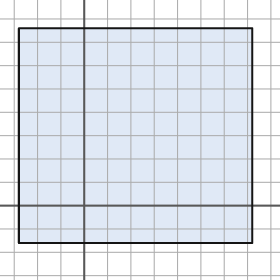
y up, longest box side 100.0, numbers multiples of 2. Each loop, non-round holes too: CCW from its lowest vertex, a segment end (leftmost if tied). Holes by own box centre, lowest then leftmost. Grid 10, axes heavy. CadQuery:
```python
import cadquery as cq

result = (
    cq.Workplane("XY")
    .moveTo(-28.0, -16.0)
    .lineTo(72.0, -16.0)
    .lineTo(72.0, 76.0)
    .lineTo(-28.0, 76.0)
    .close()
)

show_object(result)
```